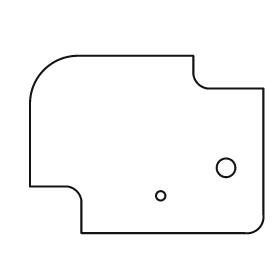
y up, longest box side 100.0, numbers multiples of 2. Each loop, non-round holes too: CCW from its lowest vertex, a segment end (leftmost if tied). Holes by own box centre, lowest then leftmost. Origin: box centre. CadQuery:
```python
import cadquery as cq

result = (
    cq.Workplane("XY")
    .moveTo(-28.0, -38.0)
    .lineTo(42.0, -38.0)
    .threePointArc((48.0, -36.0), (50.0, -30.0))
    .lineTo(50.0, 24.0)
    .lineTo(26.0, 24.0)
    .threePointArc((22.0, 26.0), (20.0, 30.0))
    .lineTo(20.0, 38.0)
    .lineTo(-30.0, 38.0)
    .threePointArc((-44.0, 32.0), (-50.0, 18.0))
    .lineTo(-50.0, -18.0)
    .lineTo(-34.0, -18.0)
    .threePointArc((-30.0, -20.0), (-28.0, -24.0))
    .close()
    .moveTo(6.0, -22.0)
    .circle(2.0)
    .moveTo(34.0, -10.0)
    .circle(4.0)
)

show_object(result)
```